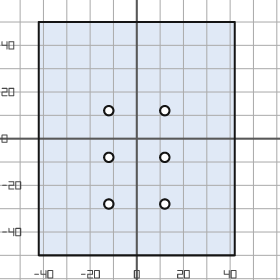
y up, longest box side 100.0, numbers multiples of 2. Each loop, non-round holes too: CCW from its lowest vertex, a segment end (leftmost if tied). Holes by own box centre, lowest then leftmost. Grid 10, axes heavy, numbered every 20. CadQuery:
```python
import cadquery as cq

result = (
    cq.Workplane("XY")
    .moveTo(-42.0, -50.0)
    .lineTo(42.0, -50.0)
    .lineTo(42.0, 50.0)
    .lineTo(-42.0, 50.0)
    .close()
    .moveTo(-12.0, -28.0)
    .circle(2.0)
    .moveTo(12.0, -28.0)
    .circle(2.0)
    .moveTo(-12.0, -8.0)
    .circle(2.0)
    .moveTo(12.0, -8.0)
    .circle(2.0)
    .moveTo(-12.0, 12.0)
    .circle(2.0)
    .moveTo(12.0, 12.0)
    .circle(2.0)
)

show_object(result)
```